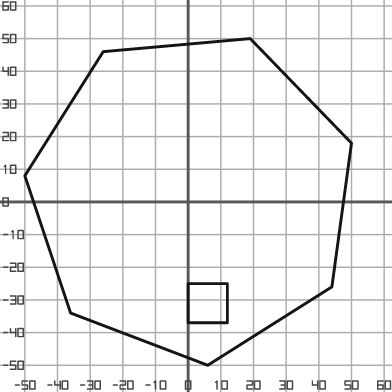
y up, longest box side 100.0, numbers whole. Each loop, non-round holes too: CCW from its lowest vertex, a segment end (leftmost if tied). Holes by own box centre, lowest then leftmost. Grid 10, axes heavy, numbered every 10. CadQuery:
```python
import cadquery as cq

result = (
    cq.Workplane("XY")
    .moveTo(6.0, -50.0)
    .lineTo(44.0, -26.0)
    .lineTo(50.0, 18.0)
    .lineTo(19.0, 50.0)
    .lineTo(-26.0, 46.0)
    .lineTo(-50.0, 8.0)
    .lineTo(-36.0, -34.0)
    .close()
    .moveTo(0.0, -37.0)
    .lineTo(12.0, -37.0)
    .lineTo(12.0, -25.0)
    .lineTo(0.0, -25.0)
    .close()
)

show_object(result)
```